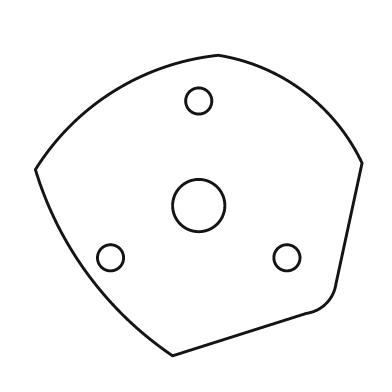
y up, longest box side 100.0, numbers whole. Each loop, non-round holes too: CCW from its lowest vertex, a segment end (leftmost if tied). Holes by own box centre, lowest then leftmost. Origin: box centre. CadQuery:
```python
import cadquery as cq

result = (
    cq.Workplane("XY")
    .moveTo(-8.0, -46.0)
    .lineTo(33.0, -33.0)
    .threePointArc((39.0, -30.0), (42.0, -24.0))
    .lineTo(50.0, 13.0)
    .threePointArc((32.0, 35.0), (6.0, 46.0))
    .threePointArc((-26.0, 35.0), (-50.0, 11.0))
    .threePointArc((-34.0, -21.0), (-8.0, -46.0))
    .close()
    .moveTo(-27.0, -16.0)
    .circle(4.0)
    .moveTo(27.0, -16.0)
    .circle(4.0)
    .moveTo(0.0, 0.0)
    .circle(8.0)
    .moveTo(0.0, 32.0)
    .circle(4.0)
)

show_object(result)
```